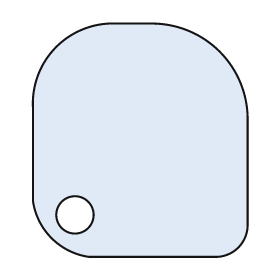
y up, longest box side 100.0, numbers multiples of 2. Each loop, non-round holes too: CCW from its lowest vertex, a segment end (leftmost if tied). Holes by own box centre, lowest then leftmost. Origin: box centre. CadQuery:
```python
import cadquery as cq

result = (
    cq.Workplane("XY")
    .moveTo(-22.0, -50.0)
    .lineTo(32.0, -50.0)
    .threePointArc((42.0, -46.0), (46.0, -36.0))
    .lineTo(46.0, 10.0)
    .threePointArc((34.0, 38.0), (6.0, 50.0))
    .lineTo(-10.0, 50.0)
    .threePointArc((-36.0, 40.0), (-46.0, 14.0))
    .lineTo(-46.0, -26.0)
    .threePointArc((-38.0, -42.0), (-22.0, -50.0))
    .close()
    .moveTo(-28.0, -32.0)
    .circle(8.0)
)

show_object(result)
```